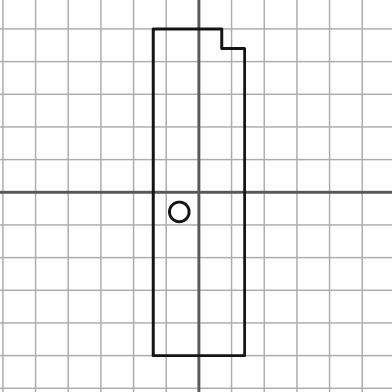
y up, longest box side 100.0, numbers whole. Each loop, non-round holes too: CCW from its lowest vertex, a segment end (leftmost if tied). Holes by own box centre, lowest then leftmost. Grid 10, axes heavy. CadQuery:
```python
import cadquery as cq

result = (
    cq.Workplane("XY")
    .moveTo(-14.0, -50.0)
    .lineTo(14.0, -50.0)
    .lineTo(14.0, 44.0)
    .lineTo(7.0, 44.0)
    .lineTo(7.0, 50.0)
    .lineTo(-14.0, 50.0)
    .close()
    .moveTo(-6.0, -6.0)
    .circle(3.0)
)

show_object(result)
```